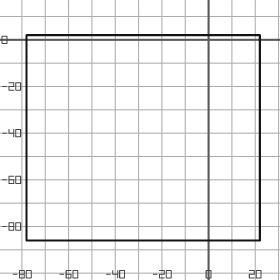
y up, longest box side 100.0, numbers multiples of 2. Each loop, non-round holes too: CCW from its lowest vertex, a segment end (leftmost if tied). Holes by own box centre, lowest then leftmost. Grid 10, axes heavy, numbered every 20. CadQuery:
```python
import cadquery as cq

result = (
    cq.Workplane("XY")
    .moveTo(-78.0, -86.0)
    .lineTo(22.0, -86.0)
    .lineTo(22.0, 2.0)
    .lineTo(-78.0, 2.0)
    .close()
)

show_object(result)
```